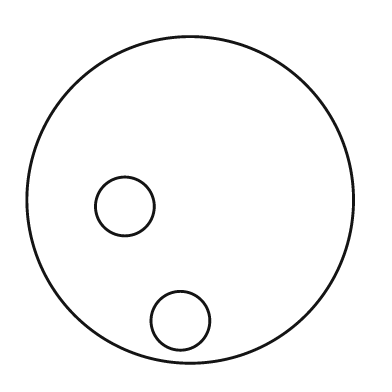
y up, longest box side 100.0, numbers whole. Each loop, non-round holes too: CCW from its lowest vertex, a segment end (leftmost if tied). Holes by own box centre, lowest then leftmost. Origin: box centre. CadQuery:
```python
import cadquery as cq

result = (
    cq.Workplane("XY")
    .moveTo(0.0, 0.0)
    .circle(50.0)
    .moveTo(-3.0, -37.0)
    .circle(9.0)
    .moveTo(-20.0, -2.0)
    .circle(9.0)
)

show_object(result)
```